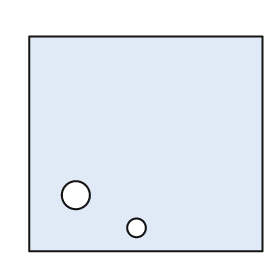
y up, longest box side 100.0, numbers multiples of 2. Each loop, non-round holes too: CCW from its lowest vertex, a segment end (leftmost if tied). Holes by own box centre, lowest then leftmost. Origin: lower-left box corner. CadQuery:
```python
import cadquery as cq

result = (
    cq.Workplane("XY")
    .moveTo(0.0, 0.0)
    .lineTo(100.0, 0.0)
    .lineTo(100.0, 92.0)
    .lineTo(0.0, 92.0)
    .close()
    .moveTo(46.0, 10.0)
    .circle(4.0)
    .moveTo(20.0, 24.0)
    .circle(6.0)
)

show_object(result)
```